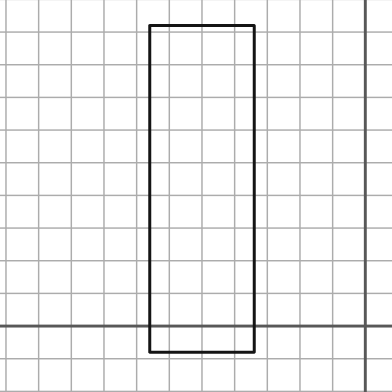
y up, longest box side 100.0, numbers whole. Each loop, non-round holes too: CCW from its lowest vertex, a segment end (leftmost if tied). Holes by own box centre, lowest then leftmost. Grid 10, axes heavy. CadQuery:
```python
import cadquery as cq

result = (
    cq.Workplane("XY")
    .moveTo(-66.0, -8.0)
    .lineTo(-34.0, -8.0)
    .lineTo(-34.0, 92.0)
    .lineTo(-66.0, 92.0)
    .close()
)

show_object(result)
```